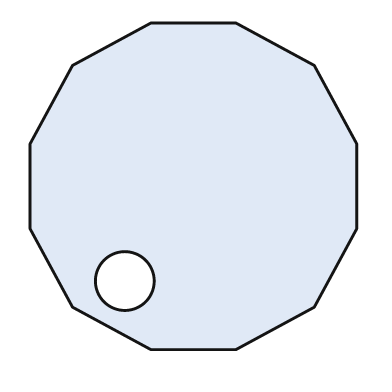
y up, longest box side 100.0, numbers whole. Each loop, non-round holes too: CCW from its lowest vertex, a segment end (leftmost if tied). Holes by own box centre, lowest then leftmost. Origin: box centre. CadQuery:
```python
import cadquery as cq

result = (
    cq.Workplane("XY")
    .moveTo(-13.0, -50.0)
    .lineTo(13.0, -50.0)
    .lineTo(37.0, -37.0)
    .lineTo(50.0, -13.0)
    .lineTo(50.0, 13.0)
    .lineTo(37.0, 37.0)
    .lineTo(13.0, 50.0)
    .lineTo(-13.0, 50.0)
    .lineTo(-37.0, 37.0)
    .lineTo(-50.0, 13.0)
    .lineTo(-50.0, -13.0)
    .lineTo(-37.0, -37.0)
    .close()
    .moveTo(-21.0, -29.0)
    .circle(9.0)
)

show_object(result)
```